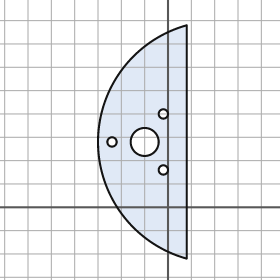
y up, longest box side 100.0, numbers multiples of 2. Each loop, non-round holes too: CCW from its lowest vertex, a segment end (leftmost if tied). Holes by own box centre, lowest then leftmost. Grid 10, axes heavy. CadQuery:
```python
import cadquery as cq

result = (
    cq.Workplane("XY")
    .moveTo(8.0, -22.0)
    .lineTo(8.0, 78.0)
    .threePointArc((-30.0, 28.0), (8.0, -22.0))
    .close()
    .moveTo(-2.0, 16.0)
    .circle(2.0)
    .moveTo(-24.0, 28.0)
    .circle(2.0)
    .moveTo(-10.0, 28.0)
    .circle(6.0)
    .moveTo(-2.0, 40.0)
    .circle(2.0)
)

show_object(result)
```